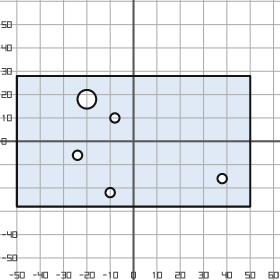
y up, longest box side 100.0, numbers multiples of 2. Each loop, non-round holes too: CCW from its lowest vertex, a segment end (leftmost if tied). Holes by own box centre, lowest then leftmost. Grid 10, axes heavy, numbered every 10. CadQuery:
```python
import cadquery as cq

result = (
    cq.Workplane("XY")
    .moveTo(-50.0, -28.0)
    .lineTo(50.0, -28.0)
    .lineTo(50.0, 28.0)
    .lineTo(-50.0, 28.0)
    .close()
    .moveTo(-10.0, -22.0)
    .circle(2.0)
    .moveTo(38.0, -16.0)
    .circle(2.0)
    .moveTo(-24.0, -6.0)
    .circle(2.0)
    .moveTo(-8.0, 10.0)
    .circle(2.0)
    .moveTo(-20.0, 18.0)
    .circle(4.0)
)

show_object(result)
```